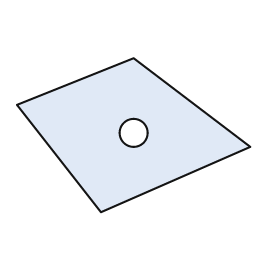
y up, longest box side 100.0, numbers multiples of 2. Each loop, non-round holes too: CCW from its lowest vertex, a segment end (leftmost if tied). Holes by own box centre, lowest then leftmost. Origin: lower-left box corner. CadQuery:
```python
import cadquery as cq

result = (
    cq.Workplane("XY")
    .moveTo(36.0, 0.0)
    .lineTo(100.0, 28.0)
    .lineTo(50.0, 66.0)
    .lineTo(0.0, 46.0)
    .close()
    .moveTo(50.0, 34.0)
    .circle(6.0)
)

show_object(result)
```